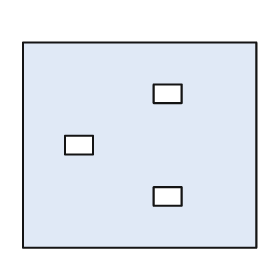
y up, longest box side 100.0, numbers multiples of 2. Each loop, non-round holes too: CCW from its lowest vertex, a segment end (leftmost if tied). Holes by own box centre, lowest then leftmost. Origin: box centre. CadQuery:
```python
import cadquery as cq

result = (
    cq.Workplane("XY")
    .moveTo(-50.0, -44.0)
    .lineTo(50.0, -44.0)
    .lineTo(50.0, 44.0)
    .lineTo(-50.0, 44.0)
    .close()
    .moveTo(6.0, -26.0)
    .lineTo(18.0, -26.0)
    .lineTo(18.0, -18.0)
    .lineTo(6.0, -18.0)
    .close()
    .moveTo(-32.0, -4.0)
    .lineTo(-20.0, -4.0)
    .lineTo(-20.0, 4.0)
    .lineTo(-32.0, 4.0)
    .close()
    .moveTo(6.0, 18.0)
    .lineTo(18.0, 18.0)
    .lineTo(18.0, 26.0)
    .lineTo(6.0, 26.0)
    .close()
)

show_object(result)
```